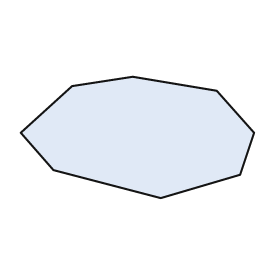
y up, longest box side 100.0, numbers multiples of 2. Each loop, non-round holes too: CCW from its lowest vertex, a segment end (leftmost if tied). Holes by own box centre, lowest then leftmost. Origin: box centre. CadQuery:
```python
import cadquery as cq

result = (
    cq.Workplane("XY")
    .moveTo(10.0, -26.0)
    .lineTo(44.0, -16.0)
    .lineTo(50.0, 2.0)
    .lineTo(34.0, 20.0)
    .lineTo(-2.0, 26.0)
    .lineTo(-28.0, 22.0)
    .lineTo(-50.0, 2.0)
    .lineTo(-36.0, -14.0)
    .close()
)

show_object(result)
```